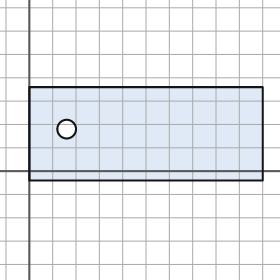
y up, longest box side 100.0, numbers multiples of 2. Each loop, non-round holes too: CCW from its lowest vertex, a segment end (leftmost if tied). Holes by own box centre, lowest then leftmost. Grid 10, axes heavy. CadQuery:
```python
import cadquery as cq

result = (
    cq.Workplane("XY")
    .moveTo(0.0, -4.0)
    .lineTo(100.0, -4.0)
    .lineTo(100.0, 36.0)
    .lineTo(0.0, 36.0)
    .close()
    .moveTo(16.0, 18.0)
    .circle(4.0)
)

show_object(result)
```